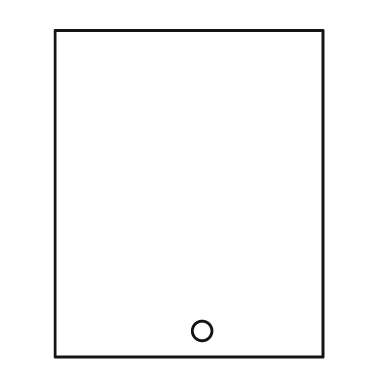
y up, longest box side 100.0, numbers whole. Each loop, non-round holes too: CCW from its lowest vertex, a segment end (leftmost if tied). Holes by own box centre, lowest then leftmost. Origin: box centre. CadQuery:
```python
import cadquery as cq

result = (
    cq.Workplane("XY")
    .moveTo(-41.0, -50.0)
    .lineTo(41.0, -50.0)
    .lineTo(41.0, 50.0)
    .lineTo(-41.0, 50.0)
    .close()
    .moveTo(4.0, -42.0)
    .circle(3.0)
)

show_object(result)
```